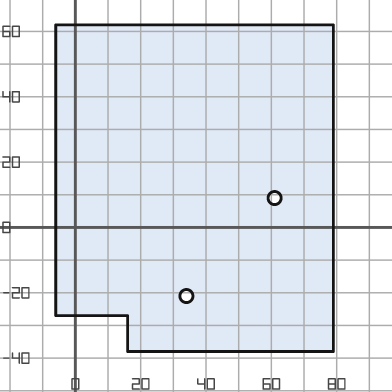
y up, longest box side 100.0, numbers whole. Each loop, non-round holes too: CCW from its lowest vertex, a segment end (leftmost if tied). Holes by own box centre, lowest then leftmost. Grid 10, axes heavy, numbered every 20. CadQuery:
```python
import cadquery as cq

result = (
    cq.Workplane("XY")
    .moveTo(16.0, -38.0)
    .lineTo(79.0, -38.0)
    .lineTo(79.0, 62.0)
    .lineTo(-6.0, 62.0)
    .lineTo(-6.0, -27.0)
    .lineTo(16.0, -27.0)
    .close()
    .moveTo(34.0, -21.0)
    .circle(2.0)
    .moveTo(61.0, 9.0)
    .circle(2.0)
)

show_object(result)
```